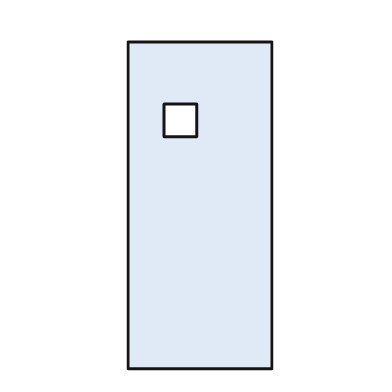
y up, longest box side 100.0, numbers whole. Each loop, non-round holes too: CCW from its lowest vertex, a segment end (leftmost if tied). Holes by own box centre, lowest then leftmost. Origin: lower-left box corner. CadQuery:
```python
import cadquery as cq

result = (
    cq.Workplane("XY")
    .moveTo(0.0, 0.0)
    .lineTo(44.0, 0.0)
    .lineTo(44.0, 100.0)
    .lineTo(0.0, 100.0)
    .close()
    .moveTo(11.0, 71.0)
    .lineTo(21.0, 71.0)
    .lineTo(21.0, 81.0)
    .lineTo(11.0, 81.0)
    .close()
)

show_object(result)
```